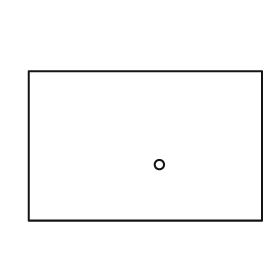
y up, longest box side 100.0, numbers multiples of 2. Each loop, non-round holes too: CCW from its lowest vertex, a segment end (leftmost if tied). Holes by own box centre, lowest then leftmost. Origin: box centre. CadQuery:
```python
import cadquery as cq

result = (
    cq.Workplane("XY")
    .moveTo(-50.0, -32.0)
    .lineTo(50.0, -32.0)
    .lineTo(50.0, 32.0)
    .lineTo(-50.0, 32.0)
    .close()
    .moveTo(6.0, -8.0)
    .circle(2.0)
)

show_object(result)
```